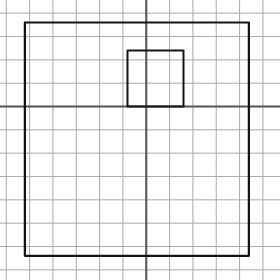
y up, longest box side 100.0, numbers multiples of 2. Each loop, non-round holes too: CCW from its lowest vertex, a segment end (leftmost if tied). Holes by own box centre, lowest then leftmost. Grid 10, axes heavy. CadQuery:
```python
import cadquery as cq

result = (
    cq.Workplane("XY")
    .moveTo(-52.0, -64.0)
    .lineTo(44.0, -64.0)
    .lineTo(44.0, 36.0)
    .lineTo(-52.0, 36.0)
    .close()
    .moveTo(-8.0, 0.0)
    .lineTo(16.0, 0.0)
    .lineTo(16.0, 24.0)
    .lineTo(-8.0, 24.0)
    .close()
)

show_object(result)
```